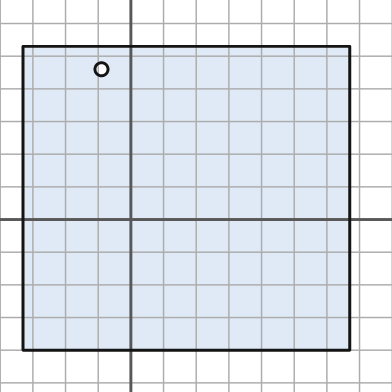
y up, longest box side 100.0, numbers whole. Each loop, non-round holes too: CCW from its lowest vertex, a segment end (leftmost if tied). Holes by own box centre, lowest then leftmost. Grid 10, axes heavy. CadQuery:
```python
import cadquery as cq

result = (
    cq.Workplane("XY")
    .moveTo(-33.0, -40.0)
    .lineTo(67.0, -40.0)
    .lineTo(67.0, 53.0)
    .lineTo(-33.0, 53.0)
    .close()
    .moveTo(-9.0, 46.0)
    .circle(2.0)
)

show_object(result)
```